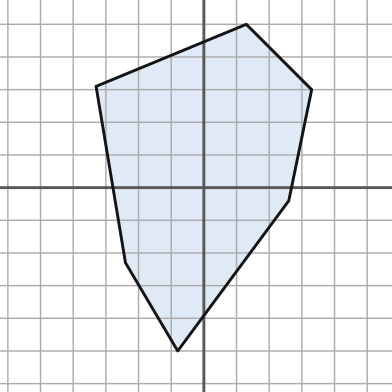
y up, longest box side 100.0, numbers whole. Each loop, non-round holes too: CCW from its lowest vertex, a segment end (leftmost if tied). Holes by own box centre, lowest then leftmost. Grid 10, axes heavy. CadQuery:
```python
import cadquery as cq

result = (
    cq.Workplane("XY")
    .moveTo(-8.0, -50.0)
    .lineTo(26.0, -4.0)
    .lineTo(33.0, 30.0)
    .lineTo(13.0, 50.0)
    .lineTo(-33.0, 31.0)
    .lineTo(-24.0, -23.0)
    .close()
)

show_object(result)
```